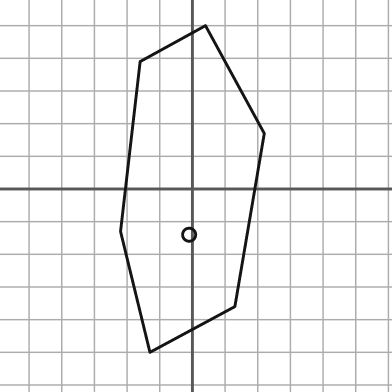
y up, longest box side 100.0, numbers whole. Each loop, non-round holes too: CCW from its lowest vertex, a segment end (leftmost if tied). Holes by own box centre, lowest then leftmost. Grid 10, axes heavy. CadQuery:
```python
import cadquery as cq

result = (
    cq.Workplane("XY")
    .moveTo(-13.0, -50.0)
    .lineTo(13.0, -36.0)
    .lineTo(22.0, 17.0)
    .lineTo(4.0, 50.0)
    .lineTo(-16.0, 39.0)
    .lineTo(-22.0, -13.0)
    .close()
    .moveTo(-1.0, -14.0)
    .circle(2.0)
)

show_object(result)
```